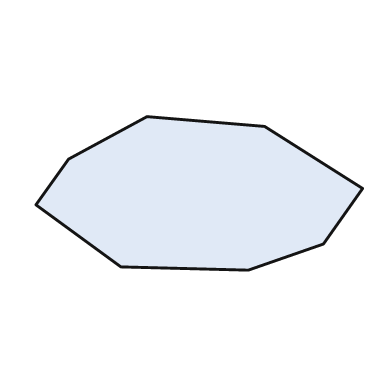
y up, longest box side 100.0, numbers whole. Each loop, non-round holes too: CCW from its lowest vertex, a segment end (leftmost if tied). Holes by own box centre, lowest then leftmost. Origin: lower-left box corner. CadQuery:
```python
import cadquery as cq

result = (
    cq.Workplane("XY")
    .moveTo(65.0, 0.0)
    .lineTo(88.0, 8.0)
    .lineTo(100.0, 25.0)
    .lineTo(70.0, 44.0)
    .lineTo(34.0, 47.0)
    .lineTo(10.0, 34.0)
    .lineTo(0.0, 20.0)
    .lineTo(26.0, 1.0)
    .close()
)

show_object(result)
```